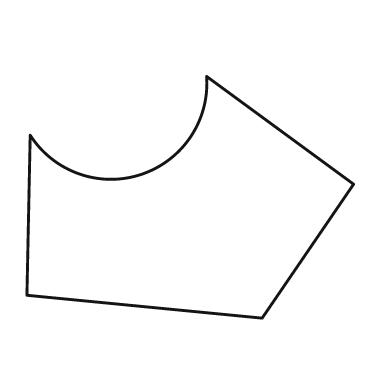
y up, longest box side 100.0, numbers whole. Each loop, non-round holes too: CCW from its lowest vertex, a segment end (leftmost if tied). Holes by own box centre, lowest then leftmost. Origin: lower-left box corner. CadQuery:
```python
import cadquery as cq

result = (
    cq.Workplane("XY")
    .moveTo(72.0, 0.0)
    .lineTo(100.0, 41.0)
    .lineTo(55.0, 74.0)
    .threePointArc((35.0, 44.0), (1.0, 56.0))
    .lineTo(0.0, 7.0)
    .close()
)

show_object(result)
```